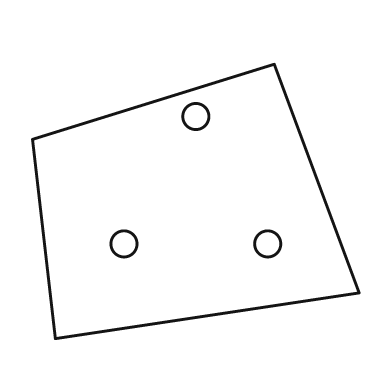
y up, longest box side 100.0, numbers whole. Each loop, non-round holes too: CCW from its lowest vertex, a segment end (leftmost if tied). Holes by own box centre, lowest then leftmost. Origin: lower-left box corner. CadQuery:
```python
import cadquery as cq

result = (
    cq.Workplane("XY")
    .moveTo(7.0, 0.0)
    .lineTo(100.0, 14.0)
    .lineTo(74.0, 84.0)
    .lineTo(0.0, 61.0)
    .close()
    .moveTo(28.0, 29.0)
    .circle(4.0)
    .moveTo(72.0, 29.0)
    .circle(4.0)
    .moveTo(50.0, 68.0)
    .circle(4.0)
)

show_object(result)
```